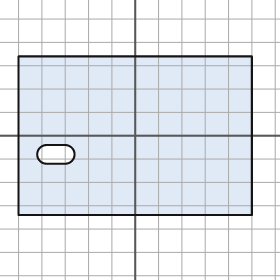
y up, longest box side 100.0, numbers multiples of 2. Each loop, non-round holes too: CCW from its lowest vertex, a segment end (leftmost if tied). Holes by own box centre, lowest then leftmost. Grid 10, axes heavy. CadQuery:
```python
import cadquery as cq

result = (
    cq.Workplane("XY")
    .moveTo(-50.0, -34.0)
    .lineTo(50.0, -34.0)
    .lineTo(50.0, 34.0)
    .lineTo(-50.0, 34.0)
    .close()
    .moveTo(-38.0, -12.0)
    .lineTo(-30.0, -12.0)
    .threePointArc((-26.0, -8.0), (-30.0, -4.0))
    .lineTo(-38.0, -4.0)
    .threePointArc((-42.0, -8.0), (-38.0, -12.0))
    .close()
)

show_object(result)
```